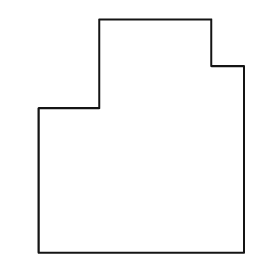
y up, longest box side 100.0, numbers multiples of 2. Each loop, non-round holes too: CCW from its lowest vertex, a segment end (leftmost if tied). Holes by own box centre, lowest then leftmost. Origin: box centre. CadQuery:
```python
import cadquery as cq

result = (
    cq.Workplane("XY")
    .moveTo(-44.0, -50.0)
    .lineTo(44.0, -50.0)
    .lineTo(44.0, 30.0)
    .lineTo(30.0, 30.0)
    .lineTo(30.0, 50.0)
    .lineTo(-18.0, 50.0)
    .lineTo(-18.0, 12.0)
    .lineTo(-44.0, 12.0)
    .close()
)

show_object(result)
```